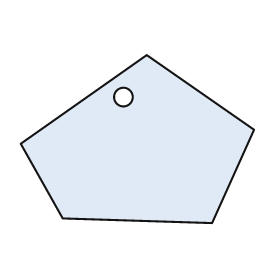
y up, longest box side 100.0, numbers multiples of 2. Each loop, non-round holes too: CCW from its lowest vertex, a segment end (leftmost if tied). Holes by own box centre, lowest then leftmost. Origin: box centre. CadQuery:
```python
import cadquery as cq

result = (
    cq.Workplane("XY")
    .moveTo(32.0, -36.0)
    .lineTo(50.0, 4.0)
    .lineTo(4.0, 36.0)
    .lineTo(-50.0, -2.0)
    .lineTo(-32.0, -34.0)
    .close()
    .moveTo(-6.0, 18.0)
    .circle(4.0)
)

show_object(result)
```